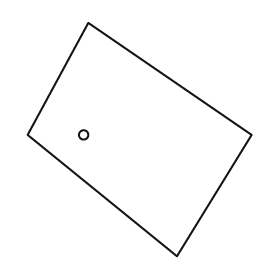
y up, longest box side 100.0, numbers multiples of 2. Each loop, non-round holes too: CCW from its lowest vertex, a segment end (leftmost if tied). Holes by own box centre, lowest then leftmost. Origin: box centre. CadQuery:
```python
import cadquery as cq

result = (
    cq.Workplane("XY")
    .moveTo(16.0, -50.0)
    .lineTo(48.0, 2.0)
    .lineTo(-22.0, 50.0)
    .lineTo(-48.0, 2.0)
    .close()
    .moveTo(-24.0, 2.0)
    .circle(2.0)
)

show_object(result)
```